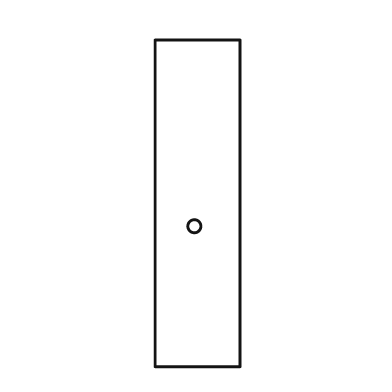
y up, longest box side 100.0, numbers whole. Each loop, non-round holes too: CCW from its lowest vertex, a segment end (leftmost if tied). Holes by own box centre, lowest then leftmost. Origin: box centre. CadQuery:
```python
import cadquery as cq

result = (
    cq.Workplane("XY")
    .moveTo(-13.0, -50.0)
    .lineTo(13.0, -50.0)
    .lineTo(13.0, 50.0)
    .lineTo(-13.0, 50.0)
    .close()
    .moveTo(-1.0, -7.0)
    .circle(2.0)
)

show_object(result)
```